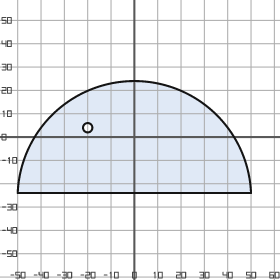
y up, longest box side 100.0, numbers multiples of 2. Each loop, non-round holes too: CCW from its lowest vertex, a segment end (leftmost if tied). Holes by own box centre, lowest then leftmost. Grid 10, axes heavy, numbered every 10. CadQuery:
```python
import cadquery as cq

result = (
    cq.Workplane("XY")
    .moveTo(-50.0, -24.0)
    .lineTo(50.0, -24.0)
    .threePointArc((0.0, 24.0), (-50.0, -24.0))
    .close()
    .moveTo(-20.0, 4.0)
    .circle(2.0)
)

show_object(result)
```